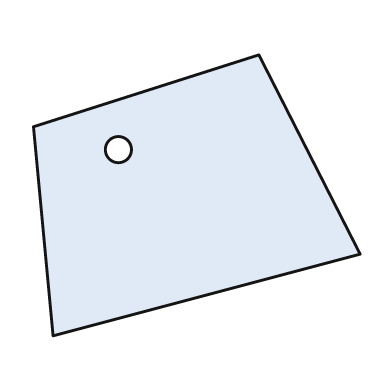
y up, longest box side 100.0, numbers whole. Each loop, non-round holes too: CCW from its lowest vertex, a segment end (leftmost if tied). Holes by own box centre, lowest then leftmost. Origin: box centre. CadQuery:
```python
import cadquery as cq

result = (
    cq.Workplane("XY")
    .moveTo(-44.0, -43.0)
    .lineTo(50.0, -18.0)
    .lineTo(19.0, 43.0)
    .lineTo(-50.0, 21.0)
    .close()
    .moveTo(-24.0, 14.0)
    .circle(4.0)
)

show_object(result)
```